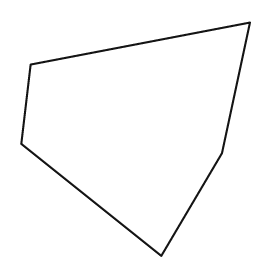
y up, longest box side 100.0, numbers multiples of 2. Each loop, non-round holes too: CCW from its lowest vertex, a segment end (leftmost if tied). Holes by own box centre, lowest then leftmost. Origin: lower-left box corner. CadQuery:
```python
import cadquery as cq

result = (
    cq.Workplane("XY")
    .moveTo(60.0, 0.0)
    .lineTo(86.0, 44.0)
    .lineTo(98.0, 100.0)
    .lineTo(4.0, 82.0)
    .lineTo(0.0, 48.0)
    .close()
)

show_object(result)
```